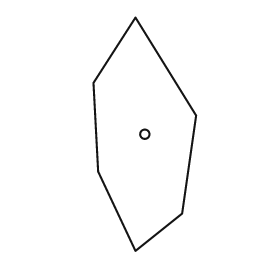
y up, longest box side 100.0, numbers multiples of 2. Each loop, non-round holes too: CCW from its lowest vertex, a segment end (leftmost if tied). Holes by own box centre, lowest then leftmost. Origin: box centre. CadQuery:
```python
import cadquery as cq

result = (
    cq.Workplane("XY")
    .moveTo(-4.0, -50.0)
    .lineTo(16.0, -34.0)
    .lineTo(22.0, 8.0)
    .lineTo(-4.0, 50.0)
    .lineTo(-22.0, 22.0)
    .lineTo(-20.0, -16.0)
    .close()
    .moveTo(0.0, 0.0)
    .circle(2.0)
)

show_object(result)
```